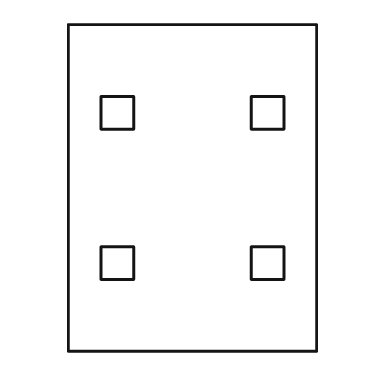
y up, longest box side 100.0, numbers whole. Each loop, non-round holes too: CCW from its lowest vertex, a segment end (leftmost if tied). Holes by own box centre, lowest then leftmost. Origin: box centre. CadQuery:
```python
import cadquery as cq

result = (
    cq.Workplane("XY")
    .moveTo(-38.0, -50.0)
    .lineTo(38.0, -50.0)
    .lineTo(38.0, 50.0)
    .lineTo(-38.0, 50.0)
    .close()
    .moveTo(-28.0, -28.0)
    .lineTo(-18.0, -28.0)
    .lineTo(-18.0, -18.0)
    .lineTo(-28.0, -18.0)
    .close()
    .moveTo(18.0, -28.0)
    .lineTo(28.0, -28.0)
    .lineTo(28.0, -18.0)
    .lineTo(18.0, -18.0)
    .close()
    .moveTo(-28.0, 18.0)
    .lineTo(-18.0, 18.0)
    .lineTo(-18.0, 28.0)
    .lineTo(-28.0, 28.0)
    .close()
    .moveTo(18.0, 18.0)
    .lineTo(28.0, 18.0)
    .lineTo(28.0, 28.0)
    .lineTo(18.0, 28.0)
    .close()
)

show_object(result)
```